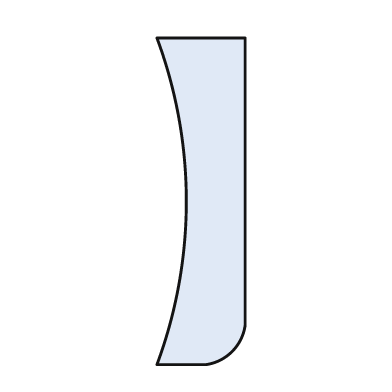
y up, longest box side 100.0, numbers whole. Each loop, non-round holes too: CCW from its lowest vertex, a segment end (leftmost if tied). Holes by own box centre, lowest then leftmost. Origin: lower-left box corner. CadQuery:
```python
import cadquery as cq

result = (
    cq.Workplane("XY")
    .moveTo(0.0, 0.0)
    .lineTo(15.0, 0.0)
    .threePointArc((23.0, 4.0), (27.0, 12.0))
    .lineTo(27.0, 100.0)
    .lineTo(0.0, 100.0)
    .threePointArc((9.0, 50.0), (0.0, 0.0))
    .close()
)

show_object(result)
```